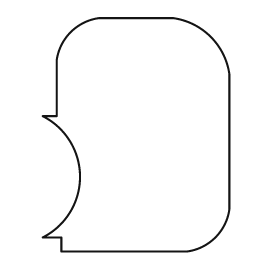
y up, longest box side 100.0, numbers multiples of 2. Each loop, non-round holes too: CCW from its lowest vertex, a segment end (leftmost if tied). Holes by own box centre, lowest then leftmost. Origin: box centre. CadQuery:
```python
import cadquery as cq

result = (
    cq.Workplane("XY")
    .moveTo(-32.0, -50.0)
    .lineTo(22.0, -50.0)
    .threePointArc((34.0, -44.0), (40.0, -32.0))
    .lineTo(40.0, 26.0)
    .threePointArc((32.0, 42.0), (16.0, 50.0))
    .lineTo(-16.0, 50.0)
    .threePointArc((-28.0, 44.0), (-34.0, 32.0))
    .lineTo(-34.0, 8.0)
    .lineTo(-40.0, 8.0)
    .threePointArc((-24.0, -18.0), (-40.0, -44.0))
    .lineTo(-32.0, -44.0)
    .close()
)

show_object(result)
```